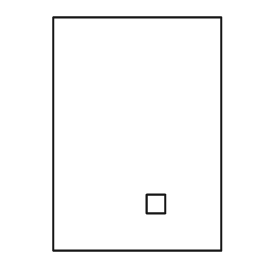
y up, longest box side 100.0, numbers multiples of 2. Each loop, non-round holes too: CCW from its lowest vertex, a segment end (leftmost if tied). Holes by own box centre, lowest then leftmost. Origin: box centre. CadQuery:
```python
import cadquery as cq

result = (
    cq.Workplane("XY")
    .moveTo(-36.0, -50.0)
    .lineTo(36.0, -50.0)
    .lineTo(36.0, 50.0)
    .lineTo(-36.0, 50.0)
    .close()
    .moveTo(4.0, -34.0)
    .lineTo(12.0, -34.0)
    .lineTo(12.0, -26.0)
    .lineTo(4.0, -26.0)
    .close()
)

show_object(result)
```